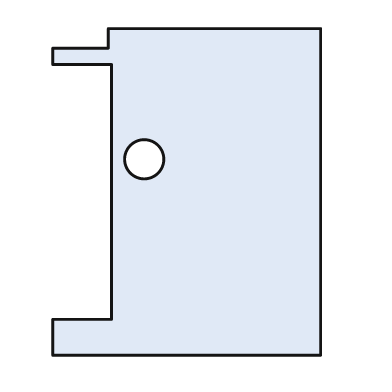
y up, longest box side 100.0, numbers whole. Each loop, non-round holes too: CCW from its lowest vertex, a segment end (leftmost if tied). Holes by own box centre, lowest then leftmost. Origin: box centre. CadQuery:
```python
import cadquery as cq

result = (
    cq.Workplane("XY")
    .moveTo(-41.0, -50.0)
    .lineTo(41.0, -50.0)
    .lineTo(41.0, 50.0)
    .lineTo(-24.0, 50.0)
    .lineTo(-24.0, 44.0)
    .lineTo(-41.0, 44.0)
    .lineTo(-41.0, 39.0)
    .lineTo(-23.0, 39.0)
    .lineTo(-23.0, -39.0)
    .lineTo(-41.0, -39.0)
    .close()
    .moveTo(-13.0, 10.0)
    .circle(6.0)
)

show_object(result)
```